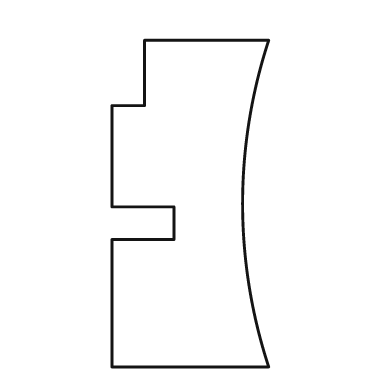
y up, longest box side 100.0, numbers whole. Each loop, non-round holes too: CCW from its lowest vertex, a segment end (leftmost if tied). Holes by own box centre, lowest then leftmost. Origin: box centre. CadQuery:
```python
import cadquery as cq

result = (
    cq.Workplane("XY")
    .moveTo(-24.0, -50.0)
    .lineTo(24.0, -50.0)
    .threePointArc((16.0, 0.0), (24.0, 50.0))
    .lineTo(-14.0, 50.0)
    .lineTo(-14.0, 30.0)
    .lineTo(-24.0, 30.0)
    .lineTo(-24.0, -1.0)
    .lineTo(-5.0, -1.0)
    .lineTo(-5.0, -11.0)
    .lineTo(-24.0, -11.0)
    .close()
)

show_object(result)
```